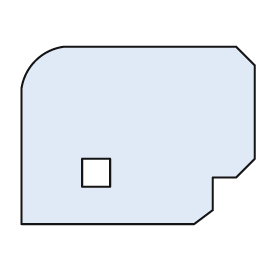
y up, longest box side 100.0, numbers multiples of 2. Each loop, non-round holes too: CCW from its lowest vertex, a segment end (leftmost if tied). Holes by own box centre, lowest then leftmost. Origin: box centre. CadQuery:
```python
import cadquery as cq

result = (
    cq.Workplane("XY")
    .moveTo(-50.0, -38.0)
    .lineTo(24.0, -38.0)
    .lineTo(32.0, -32.0)
    .lineTo(32.0, -18.0)
    .lineTo(42.0, -18.0)
    .lineTo(50.0, -10.0)
    .lineTo(50.0, 30.0)
    .lineTo(42.0, 38.0)
    .lineTo(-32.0, 38.0)
    .threePointArc((-44.0, 32.0), (-50.0, 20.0))
    .close()
    .moveTo(-24.0, -22.0)
    .lineTo(-12.0, -22.0)
    .lineTo(-12.0, -10.0)
    .lineTo(-24.0, -10.0)
    .close()
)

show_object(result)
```